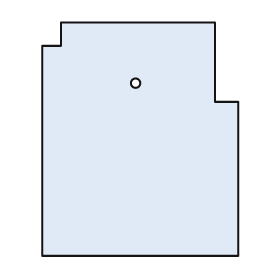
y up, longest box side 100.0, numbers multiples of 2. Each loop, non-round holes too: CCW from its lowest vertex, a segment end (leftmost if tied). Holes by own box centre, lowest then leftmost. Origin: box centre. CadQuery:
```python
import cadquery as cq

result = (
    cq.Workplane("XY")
    .moveTo(-42.0, -50.0)
    .lineTo(42.0, -50.0)
    .lineTo(42.0, 16.0)
    .lineTo(32.0, 16.0)
    .lineTo(32.0, 50.0)
    .lineTo(-34.0, 50.0)
    .lineTo(-34.0, 40.0)
    .lineTo(-42.0, 40.0)
    .close()
    .moveTo(-2.0, 24.0)
    .circle(2.0)
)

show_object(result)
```